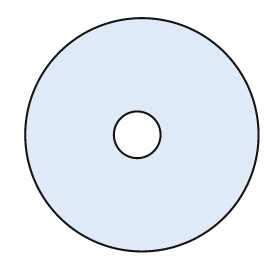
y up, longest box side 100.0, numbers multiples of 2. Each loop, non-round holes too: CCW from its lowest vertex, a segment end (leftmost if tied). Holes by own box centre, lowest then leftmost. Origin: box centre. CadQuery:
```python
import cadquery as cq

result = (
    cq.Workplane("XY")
    .moveTo(0.0, 0.0)
    .circle(50.0)
    .moveTo(-2.0, 0.0)
    .circle(10.0)
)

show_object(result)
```